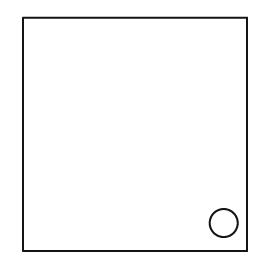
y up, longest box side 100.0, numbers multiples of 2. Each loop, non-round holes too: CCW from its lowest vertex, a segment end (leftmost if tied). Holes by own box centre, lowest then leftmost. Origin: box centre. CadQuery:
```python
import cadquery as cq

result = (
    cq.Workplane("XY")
    .moveTo(-48.0, -50.0)
    .lineTo(48.0, -50.0)
    .lineTo(48.0, 50.0)
    .lineTo(-48.0, 50.0)
    .close()
    .moveTo(38.0, -38.0)
    .circle(6.0)
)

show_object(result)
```